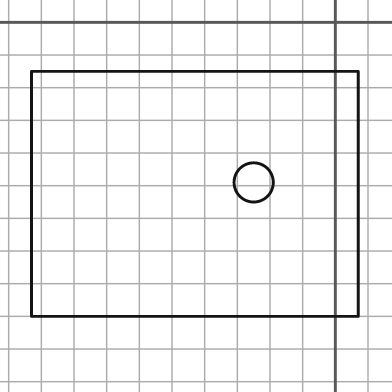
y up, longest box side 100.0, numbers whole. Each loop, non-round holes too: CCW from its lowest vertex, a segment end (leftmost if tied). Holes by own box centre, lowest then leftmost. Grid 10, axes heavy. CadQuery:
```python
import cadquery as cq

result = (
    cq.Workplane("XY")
    .moveTo(-93.0, -90.0)
    .lineTo(7.0, -90.0)
    .lineTo(7.0, -15.0)
    .lineTo(-93.0, -15.0)
    .close()
    .moveTo(-25.0, -49.0)
    .circle(6.0)
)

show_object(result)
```